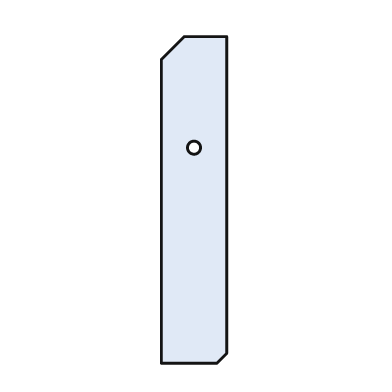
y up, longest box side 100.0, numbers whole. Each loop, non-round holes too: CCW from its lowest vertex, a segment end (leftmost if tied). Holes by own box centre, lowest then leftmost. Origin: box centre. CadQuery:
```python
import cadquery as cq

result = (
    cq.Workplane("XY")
    .moveTo(-10.0, -50.0)
    .lineTo(7.0, -50.0)
    .lineTo(10.0, -47.0)
    .lineTo(10.0, 50.0)
    .lineTo(-3.0, 50.0)
    .lineTo(-10.0, 43.0)
    .close()
    .moveTo(0.0, 16.0)
    .circle(2.0)
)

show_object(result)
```